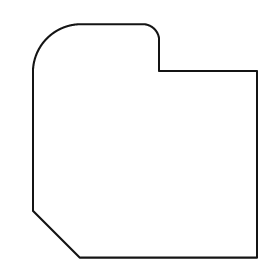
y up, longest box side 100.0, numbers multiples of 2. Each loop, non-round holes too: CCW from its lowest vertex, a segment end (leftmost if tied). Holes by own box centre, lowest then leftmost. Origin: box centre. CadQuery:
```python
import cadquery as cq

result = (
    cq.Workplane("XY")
    .moveTo(-28.0, -50.0)
    .lineTo(48.0, -50.0)
    .lineTo(48.0, 30.0)
    .lineTo(6.0, 30.0)
    .lineTo(6.0, 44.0)
    .threePointArc((4.0, 48.0), (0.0, 50.0))
    .lineTo(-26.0, 50.0)
    .threePointArc((-42.0, 44.0), (-48.0, 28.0))
    .lineTo(-48.0, -30.0)
    .close()
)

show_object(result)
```